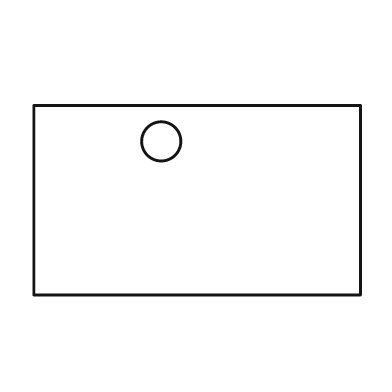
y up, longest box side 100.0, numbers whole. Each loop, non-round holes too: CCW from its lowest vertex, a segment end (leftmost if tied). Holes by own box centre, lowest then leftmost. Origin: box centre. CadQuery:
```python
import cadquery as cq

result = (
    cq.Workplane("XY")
    .moveTo(-50.0, -29.0)
    .lineTo(50.0, -29.0)
    .lineTo(50.0, 29.0)
    .lineTo(-50.0, 29.0)
    .close()
    .moveTo(-11.0, 18.0)
    .circle(6.0)
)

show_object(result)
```